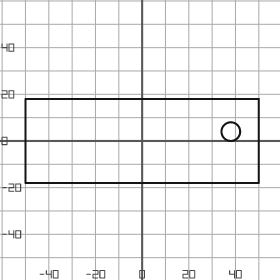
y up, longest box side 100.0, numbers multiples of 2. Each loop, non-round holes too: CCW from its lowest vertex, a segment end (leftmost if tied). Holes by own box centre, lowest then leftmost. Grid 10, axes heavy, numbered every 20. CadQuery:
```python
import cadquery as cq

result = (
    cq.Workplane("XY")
    .moveTo(-50.0, -18.0)
    .lineTo(50.0, -18.0)
    .lineTo(50.0, 18.0)
    .lineTo(-50.0, 18.0)
    .close()
    .moveTo(38.0, 4.0)
    .circle(4.0)
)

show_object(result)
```